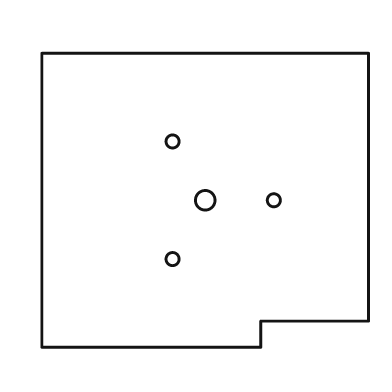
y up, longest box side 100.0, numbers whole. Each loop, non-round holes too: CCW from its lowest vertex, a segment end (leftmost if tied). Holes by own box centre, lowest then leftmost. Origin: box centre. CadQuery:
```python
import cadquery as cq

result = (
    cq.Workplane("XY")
    .moveTo(-50.0, -45.0)
    .lineTo(17.0, -45.0)
    .lineTo(17.0, -37.0)
    .lineTo(50.0, -37.0)
    .lineTo(50.0, 45.0)
    .lineTo(-50.0, 45.0)
    .close()
    .moveTo(-10.0, -18.0)
    .circle(2.0)
    .moveTo(0.0, 0.0)
    .circle(3.0)
    .moveTo(21.0, 0.0)
    .circle(2.0)
    .moveTo(-10.0, 18.0)
    .circle(2.0)
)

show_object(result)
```